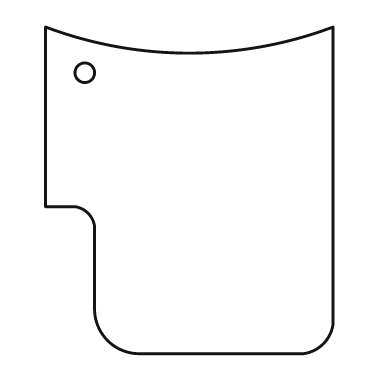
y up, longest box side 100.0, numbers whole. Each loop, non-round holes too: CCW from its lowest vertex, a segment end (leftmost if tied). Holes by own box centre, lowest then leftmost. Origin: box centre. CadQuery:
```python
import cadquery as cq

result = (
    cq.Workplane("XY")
    .moveTo(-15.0, -50.0)
    .lineTo(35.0, -50.0)
    .threePointArc((41.0, -47.0), (44.0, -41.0))
    .lineTo(44.0, 50.0)
    .threePointArc((0.0, 42.0), (-44.0, 50.0))
    .lineTo(-44.0, -5.0)
    .lineTo(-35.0, -5.0)
    .threePointArc((-31.0, -7.0), (-29.0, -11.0))
    .lineTo(-29.0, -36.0)
    .threePointArc((-25.0, -46.0), (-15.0, -50.0))
    .close()
    .moveTo(-32.0, 36.0)
    .circle(3.0)
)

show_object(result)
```